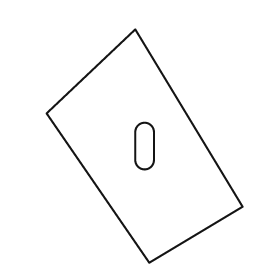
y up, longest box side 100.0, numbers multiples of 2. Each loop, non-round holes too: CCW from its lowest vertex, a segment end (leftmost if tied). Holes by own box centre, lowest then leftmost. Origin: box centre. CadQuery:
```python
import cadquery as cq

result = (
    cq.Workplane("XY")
    .moveTo(2.0, -50.0)
    .lineTo(42.0, -26.0)
    .lineTo(-4.0, 50.0)
    .lineTo(-42.0, 14.0)
    .close()
    .moveTo(-4.0, -6.0)
    .threePointArc((0.0, -10.0), (4.0, -6.0))
    .lineTo(4.0, 6.0)
    .threePointArc((0.0, 10.0), (-4.0, 6.0))
    .close()
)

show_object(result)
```